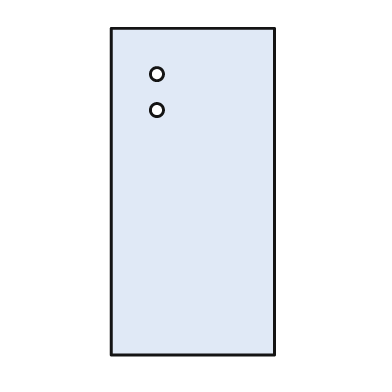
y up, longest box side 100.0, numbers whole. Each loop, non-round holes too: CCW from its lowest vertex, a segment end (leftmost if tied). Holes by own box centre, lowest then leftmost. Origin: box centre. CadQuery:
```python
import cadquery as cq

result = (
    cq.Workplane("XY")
    .moveTo(-25.0, -50.0)
    .lineTo(25.0, -50.0)
    .lineTo(25.0, 50.0)
    .lineTo(-25.0, 50.0)
    .close()
    .moveTo(-11.0, 25.0)
    .circle(2.0)
    .moveTo(-11.0, 36.0)
    .circle(2.0)
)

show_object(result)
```